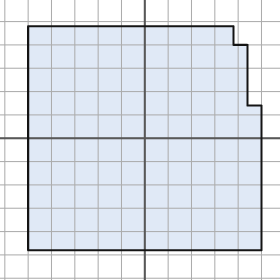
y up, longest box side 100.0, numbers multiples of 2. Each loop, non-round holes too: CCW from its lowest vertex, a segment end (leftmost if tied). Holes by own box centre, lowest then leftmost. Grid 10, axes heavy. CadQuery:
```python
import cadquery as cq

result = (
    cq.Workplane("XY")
    .moveTo(-50.0, -48.0)
    .lineTo(50.0, -48.0)
    .lineTo(50.0, 14.0)
    .lineTo(44.0, 14.0)
    .lineTo(44.0, 40.0)
    .lineTo(38.0, 40.0)
    .lineTo(38.0, 48.0)
    .lineTo(-50.0, 48.0)
    .close()
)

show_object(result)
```